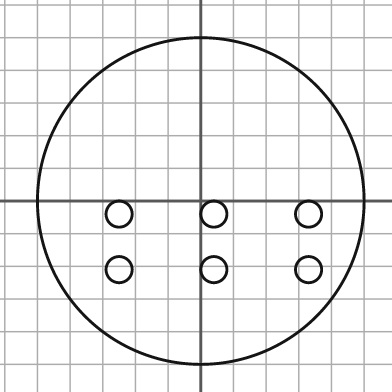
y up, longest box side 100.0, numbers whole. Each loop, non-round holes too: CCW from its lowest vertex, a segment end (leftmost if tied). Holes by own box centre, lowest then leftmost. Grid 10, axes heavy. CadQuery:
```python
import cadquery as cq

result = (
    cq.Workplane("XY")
    .moveTo(0.0, 0.0)
    .circle(50.0)
    .moveTo(-25.0, -21.0)
    .circle(4.0)
    .moveTo(4.0, -21.0)
    .circle(4.0)
    .moveTo(33.0, -21.0)
    .circle(4.0)
    .moveTo(-25.0, -4.0)
    .circle(4.0)
    .moveTo(4.0, -4.0)
    .circle(4.0)
    .moveTo(33.0, -4.0)
    .circle(4.0)
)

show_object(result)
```